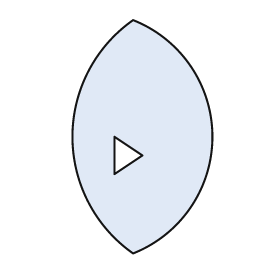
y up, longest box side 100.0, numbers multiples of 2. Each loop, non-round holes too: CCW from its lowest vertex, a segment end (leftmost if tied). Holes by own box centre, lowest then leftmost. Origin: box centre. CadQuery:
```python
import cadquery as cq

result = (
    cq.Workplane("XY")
    .moveTo(-4.0, -50.0)
    .threePointArc((30.0, 0.0), (-4.0, 50.0))
    .threePointArc((-30.0, 0.0), (-4.0, -50.0))
    .close()
    .moveTo(-12.0, -16.0)
    .lineTo(0.0, -8.0)
    .lineTo(-12.0, 0.0)
    .close()
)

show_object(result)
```